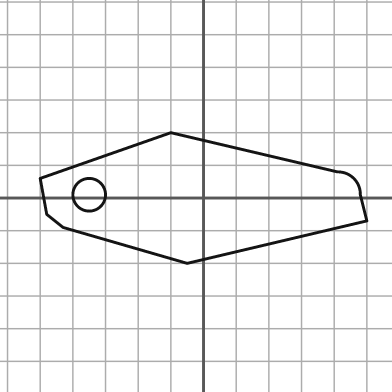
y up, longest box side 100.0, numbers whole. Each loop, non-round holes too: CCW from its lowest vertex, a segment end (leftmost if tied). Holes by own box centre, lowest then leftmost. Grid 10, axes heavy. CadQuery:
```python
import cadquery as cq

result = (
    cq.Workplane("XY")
    .moveTo(-5.0, -20.0)
    .lineTo(50.0, -7.0)
    .lineTo(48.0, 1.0)
    .threePointArc((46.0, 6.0), (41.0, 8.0))
    .lineTo(-10.0, 20.0)
    .lineTo(-50.0, 6.0)
    .lineTo(-48.0, -5.0)
    .lineTo(-43.0, -9.0)
    .close()
    .moveTo(-35.0, 1.0)
    .circle(5.0)
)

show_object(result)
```